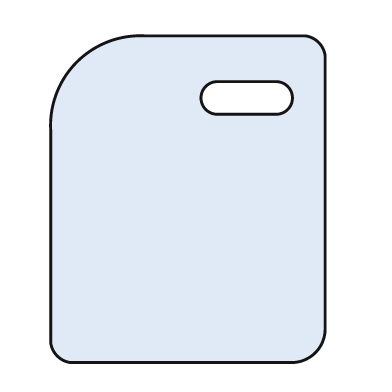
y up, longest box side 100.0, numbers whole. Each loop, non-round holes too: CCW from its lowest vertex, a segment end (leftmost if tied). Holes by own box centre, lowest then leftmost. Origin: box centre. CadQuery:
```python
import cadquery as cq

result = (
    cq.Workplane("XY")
    .moveTo(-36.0, -50.0)
    .lineTo(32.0, -50.0)
    .threePointArc((39.0, -47.0), (42.0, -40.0))
    .lineTo(42.0, 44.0)
    .threePointArc((40.0, 48.0), (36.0, 50.0))
    .lineTo(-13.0, 50.0)
    .threePointArc((-34.0, 42.0), (-42.0, 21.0))
    .lineTo(-42.0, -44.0)
    .threePointArc((-40.0, -48.0), (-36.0, -50.0))
    .close()
    .moveTo(9.0, 26.0)
    .lineTo(27.0, 26.0)
    .threePointArc((32.0, 31.0), (27.0, 36.0))
    .lineTo(9.0, 36.0)
    .threePointArc((4.0, 31.0), (9.0, 26.0))
    .close()
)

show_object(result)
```